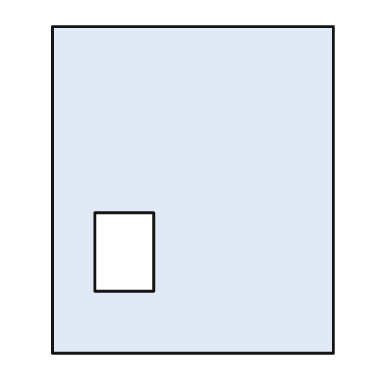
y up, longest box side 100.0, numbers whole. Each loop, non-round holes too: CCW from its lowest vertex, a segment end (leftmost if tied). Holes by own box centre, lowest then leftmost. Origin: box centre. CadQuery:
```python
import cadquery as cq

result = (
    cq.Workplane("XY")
    .moveTo(-43.0, -50.0)
    .lineTo(43.0, -50.0)
    .lineTo(43.0, 50.0)
    .lineTo(-43.0, 50.0)
    .close()
    .moveTo(-30.0, -31.0)
    .lineTo(-12.0, -31.0)
    .lineTo(-12.0, -7.0)
    .lineTo(-30.0, -7.0)
    .close()
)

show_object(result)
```